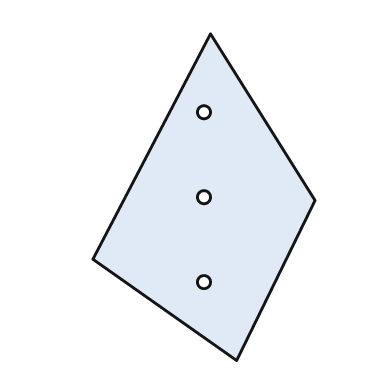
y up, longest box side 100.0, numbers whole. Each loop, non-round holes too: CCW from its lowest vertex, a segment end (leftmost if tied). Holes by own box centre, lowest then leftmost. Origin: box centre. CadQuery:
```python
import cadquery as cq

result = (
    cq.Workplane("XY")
    .moveTo(10.0, -50.0)
    .lineTo(34.0, -1.0)
    .lineTo(2.0, 50.0)
    .lineTo(-34.0, -19.0)
    .close()
    .moveTo(0.0, -26.0)
    .circle(2.0)
    .moveTo(0.0, 0.0)
    .circle(2.0)
    .moveTo(0.0, 26.0)
    .circle(2.0)
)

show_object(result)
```